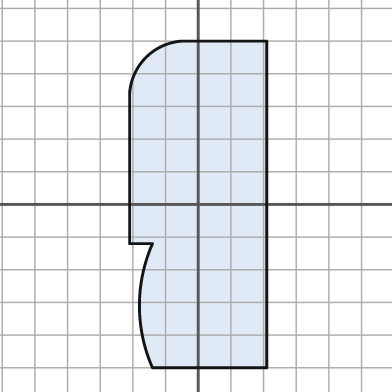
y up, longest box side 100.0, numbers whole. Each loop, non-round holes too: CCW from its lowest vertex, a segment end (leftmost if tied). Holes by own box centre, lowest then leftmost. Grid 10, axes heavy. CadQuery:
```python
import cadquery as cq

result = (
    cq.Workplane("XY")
    .moveTo(-14.0, -50.0)
    .lineTo(21.0, -50.0)
    .lineTo(21.0, 50.0)
    .lineTo(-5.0, 50.0)
    .threePointArc((-16.0, 45.0), (-21.0, 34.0))
    .lineTo(-21.0, -12.0)
    .lineTo(-14.0, -12.0)
    .threePointArc((-18.0, -31.0), (-14.0, -50.0))
    .close()
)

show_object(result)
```